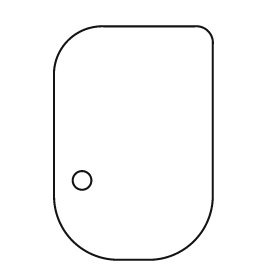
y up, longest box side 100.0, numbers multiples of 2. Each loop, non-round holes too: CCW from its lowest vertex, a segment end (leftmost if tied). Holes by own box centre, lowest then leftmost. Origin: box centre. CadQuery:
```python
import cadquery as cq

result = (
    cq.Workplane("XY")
    .moveTo(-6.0, -50.0)
    .lineTo(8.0, -50.0)
    .threePointArc((26.0, -42.0), (34.0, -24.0))
    .lineTo(34.0, 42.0)
    .threePointArc((32.0, 48.0), (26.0, 50.0))
    .lineTo(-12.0, 50.0)
    .threePointArc((-28.0, 44.0), (-34.0, 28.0))
    .lineTo(-34.0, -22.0)
    .threePointArc((-26.0, -42.0), (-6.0, -50.0))
    .close()
    .moveTo(-22.0, -16.0)
    .circle(4.0)
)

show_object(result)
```